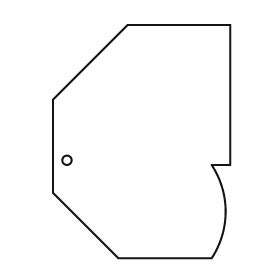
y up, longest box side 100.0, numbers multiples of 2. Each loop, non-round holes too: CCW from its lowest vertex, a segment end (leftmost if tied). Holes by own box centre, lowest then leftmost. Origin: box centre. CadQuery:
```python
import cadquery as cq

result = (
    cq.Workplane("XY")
    .moveTo(-10.0, -50.0)
    .lineTo(30.0, -50.0)
    .threePointArc((36.0, -30.0), (30.0, -10.0))
    .lineTo(38.0, -10.0)
    .lineTo(38.0, 50.0)
    .lineTo(-6.0, 50.0)
    .lineTo(-38.0, 18.0)
    .lineTo(-38.0, -22.0)
    .close()
    .moveTo(-32.0, -8.0)
    .circle(2.0)
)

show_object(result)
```